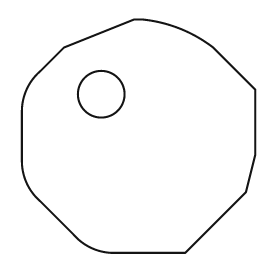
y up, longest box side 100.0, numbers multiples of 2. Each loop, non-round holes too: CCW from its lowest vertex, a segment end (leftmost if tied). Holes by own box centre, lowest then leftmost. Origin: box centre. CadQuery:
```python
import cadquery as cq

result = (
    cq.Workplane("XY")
    .moveTo(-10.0, -50.0)
    .lineTo(20.0, -50.0)
    .lineTo(46.0, -24.0)
    .lineTo(50.0, -8.0)
    .lineTo(50.0, 20.0)
    .lineTo(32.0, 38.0)
    .threePointArc((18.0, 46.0), (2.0, 50.0))
    .lineTo(-2.0, 50.0)
    .lineTo(-32.0, 38.0)
    .lineTo(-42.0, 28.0)
    .threePointArc((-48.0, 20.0), (-50.0, 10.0))
    .lineTo(-50.0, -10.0)
    .threePointArc((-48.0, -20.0), (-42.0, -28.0))
    .lineTo(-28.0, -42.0)
    .threePointArc((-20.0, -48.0), (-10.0, -50.0))
    .close()
    .moveTo(-16.0, 18.0)
    .circle(10.0)
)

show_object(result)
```